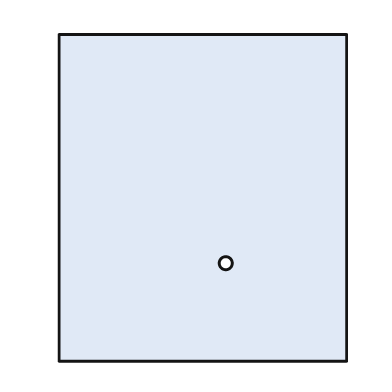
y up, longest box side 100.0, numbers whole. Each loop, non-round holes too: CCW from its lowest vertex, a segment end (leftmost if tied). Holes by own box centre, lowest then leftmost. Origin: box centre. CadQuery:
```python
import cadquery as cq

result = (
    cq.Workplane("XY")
    .moveTo(-44.0, -50.0)
    .lineTo(44.0, -50.0)
    .lineTo(44.0, 50.0)
    .lineTo(-44.0, 50.0)
    .close()
    .moveTo(7.0, -20.0)
    .circle(2.0)
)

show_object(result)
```